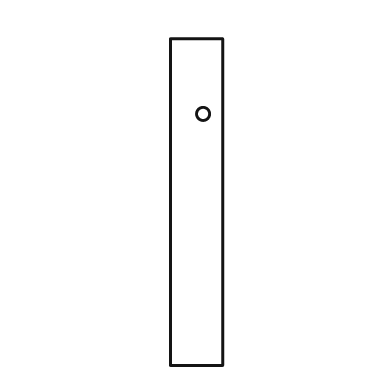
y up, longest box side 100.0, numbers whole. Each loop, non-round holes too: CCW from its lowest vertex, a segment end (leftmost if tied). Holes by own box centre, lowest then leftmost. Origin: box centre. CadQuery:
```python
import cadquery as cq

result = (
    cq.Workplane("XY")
    .moveTo(-8.0, -50.0)
    .lineTo(8.0, -50.0)
    .lineTo(8.0, 50.0)
    .lineTo(-8.0, 50.0)
    .close()
    .moveTo(2.0, 27.0)
    .circle(2.0)
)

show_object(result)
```